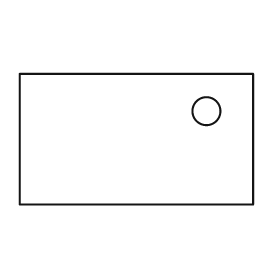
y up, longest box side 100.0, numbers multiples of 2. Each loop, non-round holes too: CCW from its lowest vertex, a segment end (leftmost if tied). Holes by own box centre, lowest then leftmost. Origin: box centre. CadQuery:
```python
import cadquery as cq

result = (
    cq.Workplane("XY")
    .moveTo(-50.0, -28.0)
    .lineTo(50.0, -28.0)
    .lineTo(50.0, 28.0)
    .lineTo(-50.0, 28.0)
    .close()
    .moveTo(30.0, 12.0)
    .circle(6.0)
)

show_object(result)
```